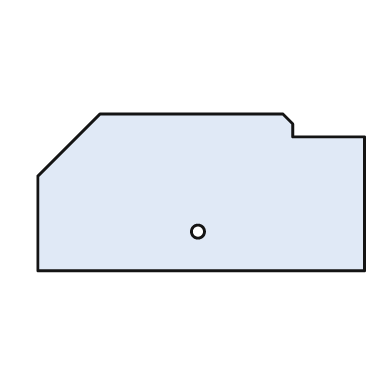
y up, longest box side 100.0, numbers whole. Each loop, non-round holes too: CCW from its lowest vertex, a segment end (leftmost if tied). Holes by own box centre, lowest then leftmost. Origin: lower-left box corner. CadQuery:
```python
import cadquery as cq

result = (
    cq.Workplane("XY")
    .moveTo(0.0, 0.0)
    .lineTo(100.0, 0.0)
    .lineTo(100.0, 41.0)
    .lineTo(78.0, 41.0)
    .lineTo(78.0, 45.0)
    .lineTo(75.0, 48.0)
    .lineTo(19.0, 48.0)
    .lineTo(0.0, 29.0)
    .close()
    .moveTo(49.0, 12.0)
    .circle(2.0)
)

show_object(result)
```